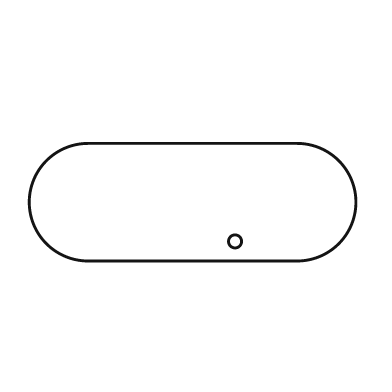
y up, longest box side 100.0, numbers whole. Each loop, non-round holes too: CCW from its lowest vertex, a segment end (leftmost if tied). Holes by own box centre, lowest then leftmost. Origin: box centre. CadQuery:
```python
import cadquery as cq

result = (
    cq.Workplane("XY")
    .moveTo(-32.0, -18.0)
    .lineTo(32.0, -18.0)
    .threePointArc((50.0, 0.0), (32.0, 18.0))
    .lineTo(-32.0, 18.0)
    .threePointArc((-50.0, 0.0), (-32.0, -18.0))
    .close()
    .moveTo(13.0, -12.0)
    .circle(2.0)
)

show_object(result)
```